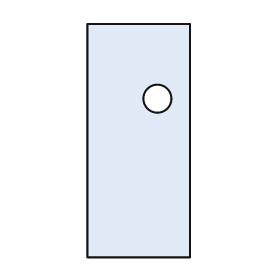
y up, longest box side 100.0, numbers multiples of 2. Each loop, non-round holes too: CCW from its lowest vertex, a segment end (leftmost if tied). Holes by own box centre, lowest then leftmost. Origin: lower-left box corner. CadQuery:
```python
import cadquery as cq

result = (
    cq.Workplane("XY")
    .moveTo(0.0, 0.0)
    .lineTo(44.0, 0.0)
    .lineTo(44.0, 100.0)
    .lineTo(0.0, 100.0)
    .close()
    .moveTo(30.0, 68.0)
    .circle(6.0)
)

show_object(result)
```